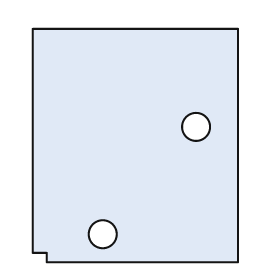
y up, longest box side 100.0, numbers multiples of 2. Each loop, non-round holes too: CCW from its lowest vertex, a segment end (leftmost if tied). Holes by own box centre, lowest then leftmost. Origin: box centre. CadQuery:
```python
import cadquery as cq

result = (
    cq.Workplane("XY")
    .moveTo(-38.0, -50.0)
    .lineTo(44.0, -50.0)
    .lineTo(44.0, 50.0)
    .lineTo(-44.0, 50.0)
    .lineTo(-44.0, -46.0)
    .lineTo(-38.0, -46.0)
    .close()
    .moveTo(-14.0, -38.0)
    .circle(6.0)
    .moveTo(26.0, 8.0)
    .circle(6.0)
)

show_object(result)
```